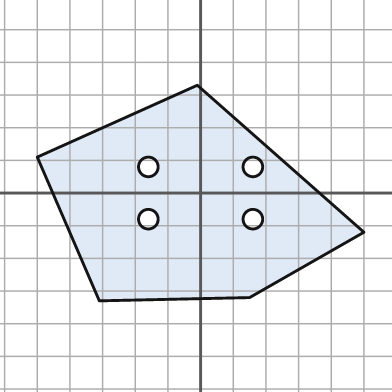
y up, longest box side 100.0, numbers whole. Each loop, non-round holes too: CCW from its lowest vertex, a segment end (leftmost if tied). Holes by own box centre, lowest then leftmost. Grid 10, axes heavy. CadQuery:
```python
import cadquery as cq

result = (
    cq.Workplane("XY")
    .moveTo(-31.0, -33.0)
    .lineTo(15.0, -32.0)
    .lineTo(50.0, -12.0)
    .lineTo(-1.0, 33.0)
    .lineTo(-50.0, 11.0)
    .close()
    .moveTo(-16.0, -8.0)
    .circle(3.0)
    .moveTo(16.0, -8.0)
    .circle(3.0)
    .moveTo(-16.0, 8.0)
    .circle(3.0)
    .moveTo(16.0, 8.0)
    .circle(3.0)
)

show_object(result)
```